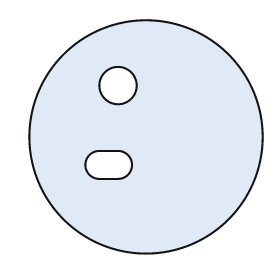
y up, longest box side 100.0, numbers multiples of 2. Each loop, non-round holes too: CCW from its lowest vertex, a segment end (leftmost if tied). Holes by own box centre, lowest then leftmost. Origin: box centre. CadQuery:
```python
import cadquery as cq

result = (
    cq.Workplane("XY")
    .moveTo(0.0, 0.0)
    .circle(50.0)
    .moveTo(-20.0, -18.0)
    .lineTo(-12.0, -18.0)
    .threePointArc((-6.0, -12.0), (-12.0, -6.0))
    .lineTo(-20.0, -6.0)
    .threePointArc((-26.0, -12.0), (-20.0, -18.0))
    .close()
    .moveTo(-12.0, 22.0)
    .circle(8.0)
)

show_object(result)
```